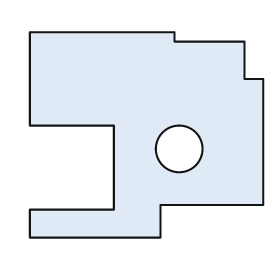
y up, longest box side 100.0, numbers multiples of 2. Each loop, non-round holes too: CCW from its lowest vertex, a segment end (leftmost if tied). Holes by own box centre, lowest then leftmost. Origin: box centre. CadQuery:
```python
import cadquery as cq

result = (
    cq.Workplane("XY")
    .moveTo(-50.0, -44.0)
    .lineTo(6.0, -44.0)
    .lineTo(6.0, -30.0)
    .lineTo(50.0, -30.0)
    .lineTo(50.0, 24.0)
    .lineTo(42.0, 24.0)
    .lineTo(42.0, 40.0)
    .lineTo(12.0, 40.0)
    .lineTo(12.0, 44.0)
    .lineTo(-50.0, 44.0)
    .lineTo(-50.0, 4.0)
    .lineTo(-14.0, 4.0)
    .lineTo(-14.0, -32.0)
    .lineTo(-50.0, -32.0)
    .close()
    .moveTo(14.0, -6.0)
    .circle(10.0)
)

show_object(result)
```